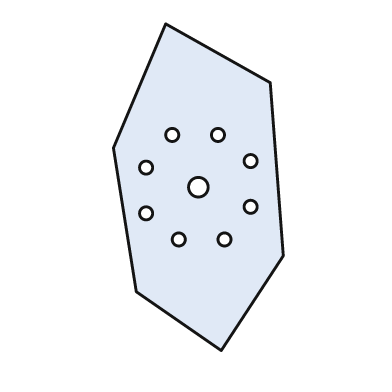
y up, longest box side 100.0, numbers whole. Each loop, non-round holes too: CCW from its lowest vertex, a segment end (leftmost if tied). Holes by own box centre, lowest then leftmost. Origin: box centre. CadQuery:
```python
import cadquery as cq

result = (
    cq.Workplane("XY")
    .moveTo(7.0, -50.0)
    .lineTo(26.0, -21.0)
    .lineTo(22.0, 32.0)
    .lineTo(-10.0, 50.0)
    .lineTo(-26.0, 12.0)
    .lineTo(-19.0, -32.0)
    .close()
    .moveTo(-6.0, -16.0)
    .circle(2.0)
    .moveTo(8.0, -16.0)
    .circle(2.0)
    .moveTo(-16.0, -8.0)
    .circle(2.0)
    .moveTo(16.0, -6.0)
    .circle(2.0)
    .moveTo(0.0, 0.0)
    .circle(3.0)
    .moveTo(-16.0, 6.0)
    .circle(2.0)
    .moveTo(16.0, 8.0)
    .circle(2.0)
    .moveTo(-8.0, 16.0)
    .circle(2.0)
    .moveTo(6.0, 16.0)
    .circle(2.0)
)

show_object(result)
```